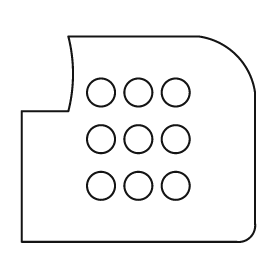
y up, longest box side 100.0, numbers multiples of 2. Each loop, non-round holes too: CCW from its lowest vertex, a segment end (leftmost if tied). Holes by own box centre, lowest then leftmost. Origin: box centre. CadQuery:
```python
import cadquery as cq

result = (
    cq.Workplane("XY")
    .moveTo(-50.0, -44.0)
    .lineTo(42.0, -44.0)
    .threePointArc((48.0, -42.0), (50.0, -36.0))
    .lineTo(50.0, 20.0)
    .threePointArc((42.0, 36.0), (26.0, 44.0))
    .lineTo(-30.0, 44.0)
    .threePointArc((-28.0, 28.0), (-30.0, 12.0))
    .lineTo(-50.0, 12.0)
    .close()
    .moveTo(-16.0, -20.0)
    .circle(6.0)
    .moveTo(0.0, -20.0)
    .circle(6.0)
    .moveTo(16.0, -20.0)
    .circle(6.0)
    .moveTo(-16.0, 0.0)
    .circle(6.0)
    .moveTo(0.0, 0.0)
    .circle(6.0)
    .moveTo(16.0, 0.0)
    .circle(6.0)
    .moveTo(-16.0, 20.0)
    .circle(6.0)
    .moveTo(0.0, 20.0)
    .circle(6.0)
    .moveTo(16.0, 20.0)
    .circle(6.0)
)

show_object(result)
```